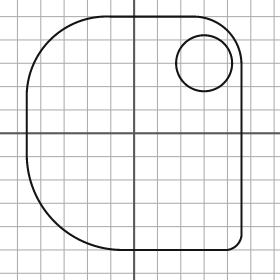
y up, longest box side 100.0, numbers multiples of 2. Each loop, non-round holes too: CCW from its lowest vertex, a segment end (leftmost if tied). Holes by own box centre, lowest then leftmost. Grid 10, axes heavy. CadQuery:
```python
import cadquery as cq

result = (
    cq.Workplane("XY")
    .moveTo(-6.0, -50.0)
    .lineTo(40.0, -50.0)
    .threePointArc((44.0, -48.0), (46.0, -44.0))
    .lineTo(46.0, 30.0)
    .threePointArc((40.0, 44.0), (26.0, 50.0))
    .lineTo(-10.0, 50.0)
    .threePointArc((-36.0, 40.0), (-46.0, 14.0))
    .lineTo(-46.0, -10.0)
    .threePointArc((-34.0, -38.0), (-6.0, -50.0))
    .close()
    .moveTo(30.0, 30.0)
    .circle(12.0)
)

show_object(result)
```